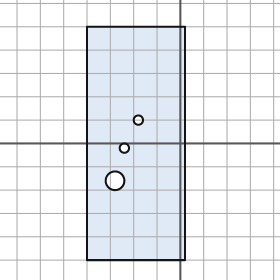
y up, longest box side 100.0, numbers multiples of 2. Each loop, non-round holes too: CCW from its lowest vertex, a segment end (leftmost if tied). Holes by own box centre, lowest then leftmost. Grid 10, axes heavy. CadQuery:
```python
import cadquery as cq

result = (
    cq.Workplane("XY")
    .moveTo(-40.0, -50.0)
    .lineTo(2.0, -50.0)
    .lineTo(2.0, 50.0)
    .lineTo(-40.0, 50.0)
    .close()
    .moveTo(-28.0, -16.0)
    .circle(4.0)
    .moveTo(-24.0, -2.0)
    .circle(2.0)
    .moveTo(-18.0, 10.0)
    .circle(2.0)
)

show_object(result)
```